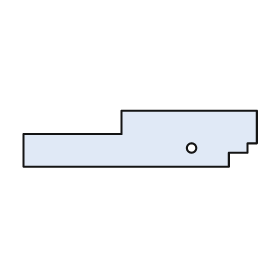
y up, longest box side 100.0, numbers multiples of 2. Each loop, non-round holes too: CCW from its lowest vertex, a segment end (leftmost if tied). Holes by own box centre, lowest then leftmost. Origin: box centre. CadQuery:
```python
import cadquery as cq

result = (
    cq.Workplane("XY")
    .moveTo(-50.0, -12.0)
    .lineTo(38.0, -12.0)
    .lineTo(38.0, -6.0)
    .lineTo(46.0, -6.0)
    .lineTo(46.0, -2.0)
    .lineTo(50.0, -2.0)
    .lineTo(50.0, 12.0)
    .lineTo(-8.0, 12.0)
    .lineTo(-8.0, 2.0)
    .lineTo(-50.0, 2.0)
    .close()
    .moveTo(22.0, -4.0)
    .circle(2.0)
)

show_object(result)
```